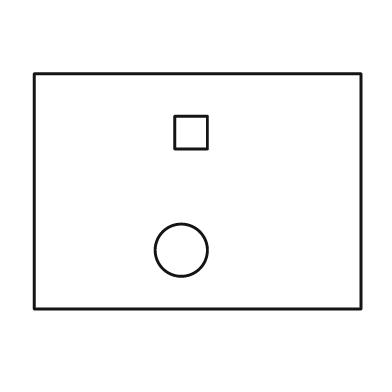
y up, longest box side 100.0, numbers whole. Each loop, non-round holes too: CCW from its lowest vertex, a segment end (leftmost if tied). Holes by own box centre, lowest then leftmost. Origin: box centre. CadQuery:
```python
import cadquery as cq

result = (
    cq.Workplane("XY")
    .moveTo(-50.0, -36.0)
    .lineTo(50.0, -36.0)
    .lineTo(50.0, 36.0)
    .lineTo(-50.0, 36.0)
    .close()
    .moveTo(-5.0, -18.0)
    .circle(8.0)
    .moveTo(-7.0, 13.0)
    .lineTo(3.0, 13.0)
    .lineTo(3.0, 23.0)
    .lineTo(-7.0, 23.0)
    .close()
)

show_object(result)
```